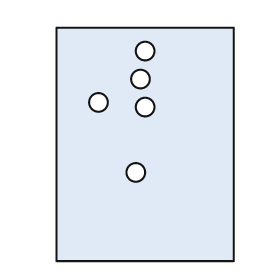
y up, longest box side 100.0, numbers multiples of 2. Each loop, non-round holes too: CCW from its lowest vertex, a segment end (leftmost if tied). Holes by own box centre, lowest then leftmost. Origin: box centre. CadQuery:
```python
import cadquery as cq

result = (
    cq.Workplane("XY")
    .moveTo(-38.0, -50.0)
    .lineTo(38.0, -50.0)
    .lineTo(38.0, 50.0)
    .lineTo(-38.0, 50.0)
    .close()
    .moveTo(-4.0, -12.0)
    .circle(4.0)
    .moveTo(0.0, 16.0)
    .circle(4.0)
    .moveTo(-20.0, 18.0)
    .circle(4.0)
    .moveTo(-2.0, 28.0)
    .circle(4.0)
    .moveTo(0.0, 40.0)
    .circle(4.0)
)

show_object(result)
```